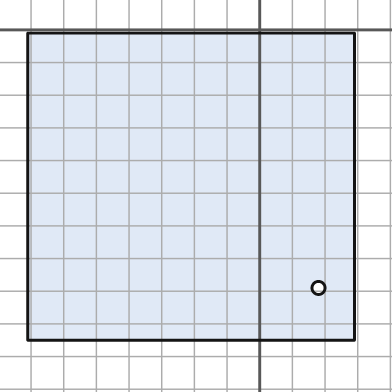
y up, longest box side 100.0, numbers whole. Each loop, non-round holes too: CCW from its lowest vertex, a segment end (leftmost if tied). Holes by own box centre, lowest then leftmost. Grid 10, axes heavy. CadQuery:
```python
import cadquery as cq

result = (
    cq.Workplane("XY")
    .moveTo(-71.0, -95.0)
    .lineTo(29.0, -95.0)
    .lineTo(29.0, -1.0)
    .lineTo(-71.0, -1.0)
    .close()
    .moveTo(18.0, -79.0)
    .circle(2.0)
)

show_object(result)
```